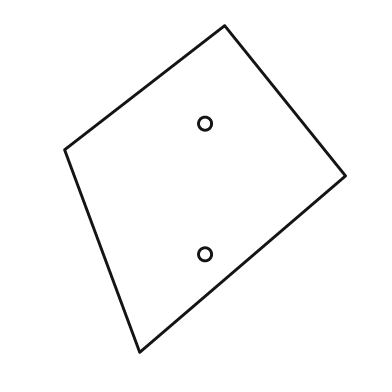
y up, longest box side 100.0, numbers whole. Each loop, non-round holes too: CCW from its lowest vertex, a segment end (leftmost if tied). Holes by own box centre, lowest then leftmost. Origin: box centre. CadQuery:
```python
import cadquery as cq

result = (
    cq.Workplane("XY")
    .moveTo(-20.0, -50.0)
    .lineTo(43.0, 4.0)
    .lineTo(6.0, 50.0)
    .lineTo(-43.0, 12.0)
    .close()
    .moveTo(0.0, -20.0)
    .circle(2.0)
    .moveTo(0.0, 20.0)
    .circle(2.0)
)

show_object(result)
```